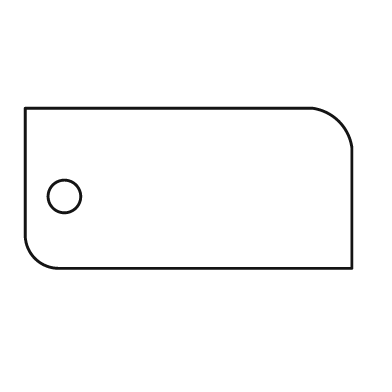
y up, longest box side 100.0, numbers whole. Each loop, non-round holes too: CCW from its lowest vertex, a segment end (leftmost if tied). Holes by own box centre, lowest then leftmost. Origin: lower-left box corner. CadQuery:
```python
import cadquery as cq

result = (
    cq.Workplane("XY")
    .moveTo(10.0, 0.0)
    .lineTo(100.0, 0.0)
    .lineTo(100.0, 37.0)
    .threePointArc((96.0, 45.0), (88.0, 49.0))
    .lineTo(0.0, 49.0)
    .lineTo(0.0, 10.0)
    .threePointArc((3.0, 3.0), (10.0, 0.0))
    .close()
    .moveTo(12.0, 22.0)
    .circle(5.0)
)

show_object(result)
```